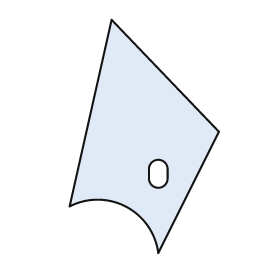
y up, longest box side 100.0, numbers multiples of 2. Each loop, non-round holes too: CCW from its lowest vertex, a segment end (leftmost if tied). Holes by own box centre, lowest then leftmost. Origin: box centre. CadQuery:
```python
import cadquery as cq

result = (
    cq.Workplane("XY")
    .moveTo(6.0, -50.0)
    .lineTo(32.0, 2.0)
    .lineTo(-14.0, 50.0)
    .lineTo(-32.0, -30.0)
    .threePointArc((-8.0, -30.0), (6.0, -50.0))
    .close()
    .moveTo(2.0, -18.0)
    .threePointArc((6.0, -22.0), (10.0, -18.0))
    .lineTo(10.0, -14.0)
    .threePointArc((6.0, -10.0), (2.0, -14.0))
    .close()
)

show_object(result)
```